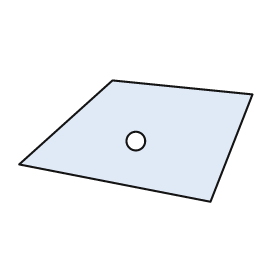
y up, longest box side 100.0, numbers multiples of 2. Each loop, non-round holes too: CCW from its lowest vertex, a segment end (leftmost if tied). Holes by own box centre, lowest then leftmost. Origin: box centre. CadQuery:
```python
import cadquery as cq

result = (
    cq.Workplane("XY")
    .moveTo(32.0, -26.0)
    .lineTo(50.0, 20.0)
    .lineTo(-10.0, 26.0)
    .lineTo(-50.0, -10.0)
    .close()
    .moveTo(0.0, 0.0)
    .circle(4.0)
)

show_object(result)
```